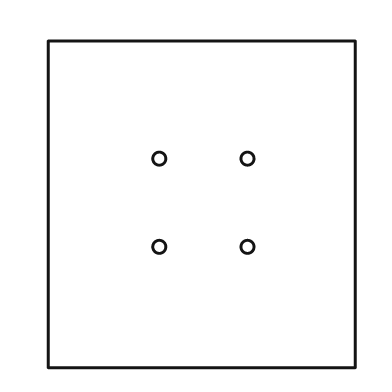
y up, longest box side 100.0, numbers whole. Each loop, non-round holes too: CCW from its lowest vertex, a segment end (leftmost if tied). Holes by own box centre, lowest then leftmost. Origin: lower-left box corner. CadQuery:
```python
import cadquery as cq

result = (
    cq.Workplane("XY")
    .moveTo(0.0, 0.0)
    .lineTo(94.0, 0.0)
    .lineTo(94.0, 100.0)
    .lineTo(0.0, 100.0)
    .close()
    .moveTo(34.0, 37.0)
    .circle(2.0)
    .moveTo(61.0, 37.0)
    .circle(2.0)
    .moveTo(34.0, 64.0)
    .circle(2.0)
    .moveTo(61.0, 64.0)
    .circle(2.0)
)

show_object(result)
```